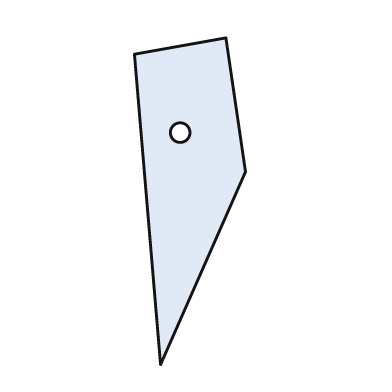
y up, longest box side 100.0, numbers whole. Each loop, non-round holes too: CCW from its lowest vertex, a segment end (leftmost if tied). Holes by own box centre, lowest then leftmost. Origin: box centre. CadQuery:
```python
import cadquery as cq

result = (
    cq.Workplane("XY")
    .moveTo(-9.0, -50.0)
    .lineTo(17.0, 9.0)
    .lineTo(11.0, 50.0)
    .lineTo(-17.0, 45.0)
    .close()
    .moveTo(-3.0, 21.0)
    .circle(3.0)
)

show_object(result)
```